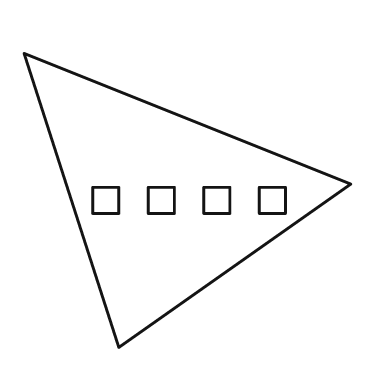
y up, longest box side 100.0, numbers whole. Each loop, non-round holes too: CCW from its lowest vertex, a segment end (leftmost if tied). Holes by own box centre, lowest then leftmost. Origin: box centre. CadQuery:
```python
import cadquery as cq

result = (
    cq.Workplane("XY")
    .moveTo(-21.0, -45.0)
    .lineTo(50.0, 5.0)
    .lineTo(-50.0, 45.0)
    .close()
    .moveTo(-29.0, -4.0)
    .lineTo(-21.0, -4.0)
    .lineTo(-21.0, 4.0)
    .lineTo(-29.0, 4.0)
    .close()
    .moveTo(-12.0, -4.0)
    .lineTo(-4.0, -4.0)
    .lineTo(-4.0, 4.0)
    .lineTo(-12.0, 4.0)
    .close()
    .moveTo(5.0, -4.0)
    .lineTo(13.0, -4.0)
    .lineTo(13.0, 4.0)
    .lineTo(5.0, 4.0)
    .close()
    .moveTo(22.0, -4.0)
    .lineTo(30.0, -4.0)
    .lineTo(30.0, 4.0)
    .lineTo(22.0, 4.0)
    .close()
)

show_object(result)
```